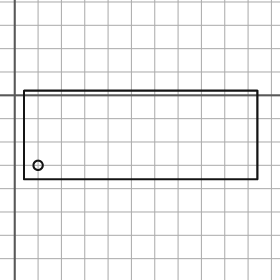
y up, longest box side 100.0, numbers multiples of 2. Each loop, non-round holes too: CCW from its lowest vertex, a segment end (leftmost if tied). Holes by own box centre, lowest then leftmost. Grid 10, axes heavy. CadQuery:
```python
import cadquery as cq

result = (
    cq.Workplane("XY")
    .moveTo(4.0, -36.0)
    .lineTo(104.0, -36.0)
    .lineTo(104.0, 2.0)
    .lineTo(4.0, 2.0)
    .close()
    .moveTo(10.0, -30.0)
    .circle(2.0)
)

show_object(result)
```